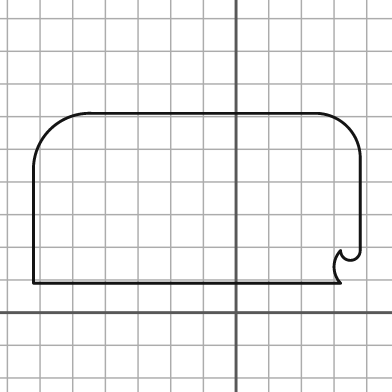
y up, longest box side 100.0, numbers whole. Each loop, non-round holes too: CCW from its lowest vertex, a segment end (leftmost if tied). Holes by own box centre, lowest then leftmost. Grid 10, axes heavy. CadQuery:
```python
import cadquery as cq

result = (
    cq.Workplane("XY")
    .moveTo(-62.0, 9.0)
    .lineTo(32.0, 9.0)
    .threePointArc((30.0, 14.0), (32.0, 19.0))
    .threePointArc((35.0, 16.0), (38.0, 19.0))
    .lineTo(38.0, 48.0)
    .threePointArc((34.0, 57.0), (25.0, 61.0))
    .lineTo(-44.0, 61.0)
    .threePointArc((-57.0, 56.0), (-62.0, 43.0))
    .close()
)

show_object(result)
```